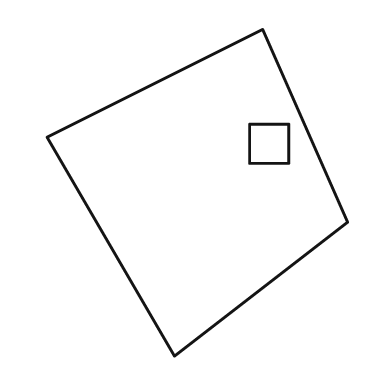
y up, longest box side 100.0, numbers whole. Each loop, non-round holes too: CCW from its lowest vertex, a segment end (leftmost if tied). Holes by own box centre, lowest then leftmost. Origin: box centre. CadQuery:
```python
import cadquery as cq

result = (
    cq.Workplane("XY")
    .moveTo(-7.0, -50.0)
    .lineTo(46.0, -9.0)
    .lineTo(20.0, 50.0)
    .lineTo(-46.0, 17.0)
    .close()
    .moveTo(16.0, 9.0)
    .lineTo(28.0, 9.0)
    .lineTo(28.0, 21.0)
    .lineTo(16.0, 21.0)
    .close()
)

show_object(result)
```